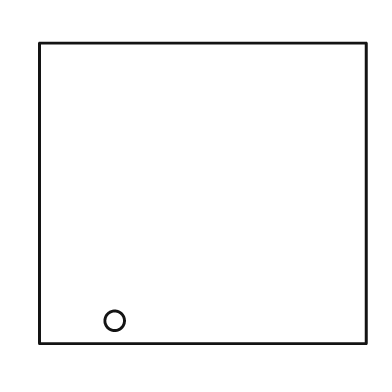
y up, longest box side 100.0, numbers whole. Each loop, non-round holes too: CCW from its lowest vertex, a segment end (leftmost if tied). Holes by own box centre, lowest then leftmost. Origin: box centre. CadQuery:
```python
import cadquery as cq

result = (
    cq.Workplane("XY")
    .moveTo(-50.0, -46.0)
    .lineTo(50.0, -46.0)
    .lineTo(50.0, 46.0)
    .lineTo(-50.0, 46.0)
    .close()
    .moveTo(-27.0, -39.0)
    .circle(3.0)
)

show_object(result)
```